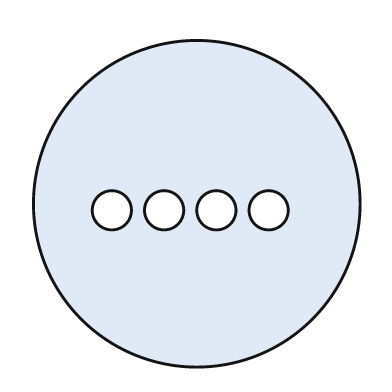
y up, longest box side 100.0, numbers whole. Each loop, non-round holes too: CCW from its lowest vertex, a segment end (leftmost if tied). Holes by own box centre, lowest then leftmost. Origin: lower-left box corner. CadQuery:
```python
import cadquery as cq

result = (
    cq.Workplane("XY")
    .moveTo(50.0, 50.0)
    .circle(50.0)
    .moveTo(24.0, 48.0)
    .circle(6.0)
    .moveTo(40.0, 48.0)
    .circle(6.0)
    .moveTo(56.0, 48.0)
    .circle(6.0)
    .moveTo(72.0, 48.0)
    .circle(6.0)
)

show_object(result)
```